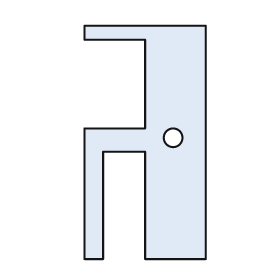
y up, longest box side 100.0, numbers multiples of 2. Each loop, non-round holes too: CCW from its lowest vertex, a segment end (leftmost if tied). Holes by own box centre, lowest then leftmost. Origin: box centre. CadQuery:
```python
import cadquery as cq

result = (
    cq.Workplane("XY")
    .moveTo(-26.0, -50.0)
    .lineTo(-18.0, -50.0)
    .lineTo(-18.0, -4.0)
    .lineTo(0.0, -4.0)
    .lineTo(0.0, -50.0)
    .lineTo(26.0, -50.0)
    .lineTo(26.0, 50.0)
    .lineTo(-26.0, 50.0)
    .lineTo(-26.0, 44.0)
    .lineTo(0.0, 44.0)
    .lineTo(0.0, 6.0)
    .lineTo(-26.0, 6.0)
    .close()
    .moveTo(12.0, 2.0)
    .circle(4.0)
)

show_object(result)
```